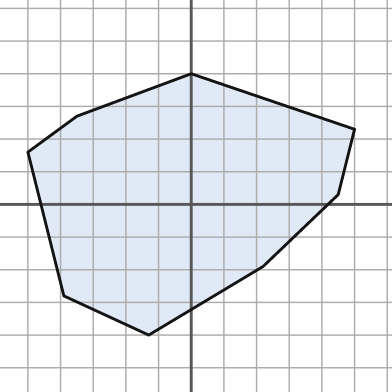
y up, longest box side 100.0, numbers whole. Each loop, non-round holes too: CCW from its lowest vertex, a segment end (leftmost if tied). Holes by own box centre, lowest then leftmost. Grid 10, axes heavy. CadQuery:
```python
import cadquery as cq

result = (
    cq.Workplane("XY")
    .moveTo(-13.0, -40.0)
    .lineTo(22.0, -19.0)
    .lineTo(45.0, 3.0)
    .lineTo(50.0, 23.0)
    .lineTo(0.0, 40.0)
    .lineTo(-35.0, 27.0)
    .lineTo(-50.0, 16.0)
    .lineTo(-39.0, -28.0)
    .close()
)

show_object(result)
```